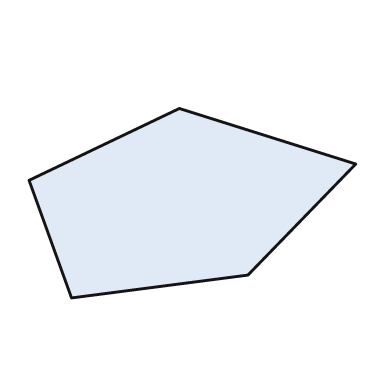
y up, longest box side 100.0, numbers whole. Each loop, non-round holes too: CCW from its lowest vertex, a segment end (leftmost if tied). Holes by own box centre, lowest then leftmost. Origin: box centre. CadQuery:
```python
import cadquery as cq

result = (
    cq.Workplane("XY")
    .moveTo(-37.0, -29.0)
    .lineTo(17.0, -22.0)
    .lineTo(50.0, 12.0)
    .lineTo(-4.0, 29.0)
    .lineTo(-50.0, 7.0)
    .close()
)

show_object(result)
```